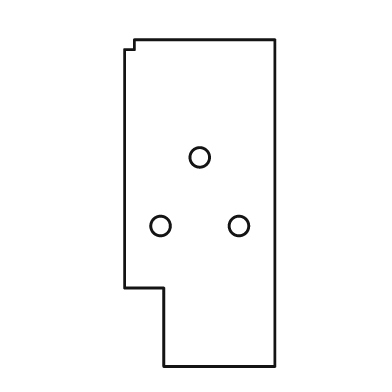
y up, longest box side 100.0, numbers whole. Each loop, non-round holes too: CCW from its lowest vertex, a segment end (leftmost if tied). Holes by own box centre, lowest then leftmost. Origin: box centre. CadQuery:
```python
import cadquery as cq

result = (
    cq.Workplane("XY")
    .moveTo(-11.0, -50.0)
    .lineTo(23.0, -50.0)
    .lineTo(23.0, 50.0)
    .lineTo(-20.0, 50.0)
    .lineTo(-20.0, 47.0)
    .lineTo(-23.0, 47.0)
    .lineTo(-23.0, -26.0)
    .lineTo(-11.0, -26.0)
    .close()
    .moveTo(-12.0, -7.0)
    .circle(3.0)
    .moveTo(12.0, -7.0)
    .circle(3.0)
    .moveTo(0.0, 14.0)
    .circle(3.0)
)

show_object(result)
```